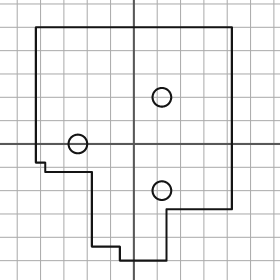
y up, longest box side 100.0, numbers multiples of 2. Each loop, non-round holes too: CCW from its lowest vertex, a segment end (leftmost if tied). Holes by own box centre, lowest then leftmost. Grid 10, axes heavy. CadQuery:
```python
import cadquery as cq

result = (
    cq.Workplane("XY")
    .moveTo(-6.0, -50.0)
    .lineTo(14.0, -50.0)
    .lineTo(14.0, -28.0)
    .lineTo(42.0, -28.0)
    .lineTo(42.0, 50.0)
    .lineTo(-42.0, 50.0)
    .lineTo(-42.0, -8.0)
    .lineTo(-38.0, -8.0)
    .lineTo(-38.0, -12.0)
    .lineTo(-18.0, -12.0)
    .lineTo(-18.0, -44.0)
    .lineTo(-6.0, -44.0)
    .close()
    .moveTo(12.0, -20.0)
    .circle(4.0)
    .moveTo(-24.0, 0.0)
    .circle(4.0)
    .moveTo(12.0, 20.0)
    .circle(4.0)
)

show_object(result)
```